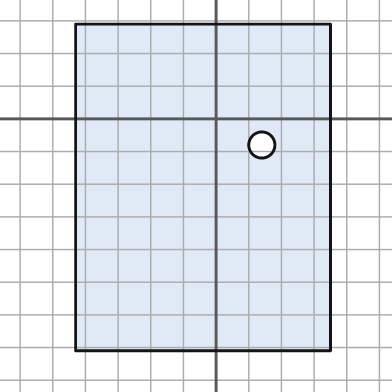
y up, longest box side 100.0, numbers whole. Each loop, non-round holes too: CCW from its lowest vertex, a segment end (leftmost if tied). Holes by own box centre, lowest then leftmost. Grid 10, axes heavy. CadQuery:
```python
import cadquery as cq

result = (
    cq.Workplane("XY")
    .moveTo(-43.0, -71.0)
    .lineTo(35.0, -71.0)
    .lineTo(35.0, 29.0)
    .lineTo(-43.0, 29.0)
    .close()
    .moveTo(14.0, -8.0)
    .circle(4.0)
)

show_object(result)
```